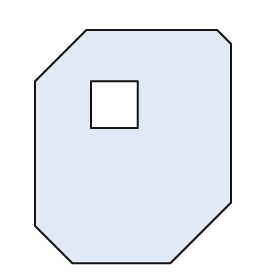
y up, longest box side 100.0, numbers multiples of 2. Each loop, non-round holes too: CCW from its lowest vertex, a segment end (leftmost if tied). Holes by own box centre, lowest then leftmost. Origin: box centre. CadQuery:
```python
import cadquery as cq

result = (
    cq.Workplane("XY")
    .moveTo(-26.0, -50.0)
    .lineTo(16.0, -50.0)
    .lineTo(42.0, -24.0)
    .lineTo(42.0, 44.0)
    .lineTo(36.0, 50.0)
    .lineTo(-20.0, 50.0)
    .lineTo(-42.0, 28.0)
    .lineTo(-42.0, -34.0)
    .close()
    .moveTo(-18.0, 8.0)
    .lineTo(2.0, 8.0)
    .lineTo(2.0, 28.0)
    .lineTo(-18.0, 28.0)
    .close()
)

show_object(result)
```